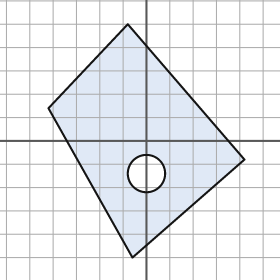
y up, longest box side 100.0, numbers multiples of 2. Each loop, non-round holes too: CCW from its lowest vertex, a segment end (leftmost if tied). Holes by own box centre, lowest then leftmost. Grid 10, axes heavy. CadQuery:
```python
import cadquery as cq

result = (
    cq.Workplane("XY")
    .moveTo(-6.0, -50.0)
    .lineTo(42.0, -8.0)
    .lineTo(-8.0, 50.0)
    .lineTo(-42.0, 14.0)
    .close()
    .moveTo(0.0, -14.0)
    .circle(8.0)
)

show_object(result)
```